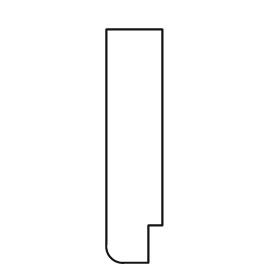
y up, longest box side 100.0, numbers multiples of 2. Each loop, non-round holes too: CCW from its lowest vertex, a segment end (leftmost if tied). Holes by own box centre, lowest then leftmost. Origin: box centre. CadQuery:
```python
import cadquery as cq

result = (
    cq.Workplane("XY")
    .moveTo(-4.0, -50.0)
    .lineTo(6.0, -50.0)
    .lineTo(6.0, -34.0)
    .lineTo(12.0, -34.0)
    .lineTo(12.0, 50.0)
    .lineTo(-12.0, 50.0)
    .lineTo(-12.0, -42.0)
    .threePointArc((-10.0, -48.0), (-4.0, -50.0))
    .close()
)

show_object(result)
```